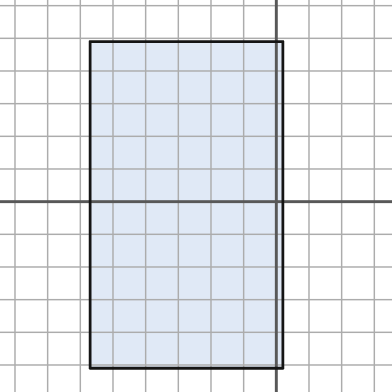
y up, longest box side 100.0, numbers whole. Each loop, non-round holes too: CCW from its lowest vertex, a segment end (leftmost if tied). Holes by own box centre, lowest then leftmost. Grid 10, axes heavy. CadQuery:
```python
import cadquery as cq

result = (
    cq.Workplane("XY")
    .moveTo(-57.0, -51.0)
    .lineTo(2.0, -51.0)
    .lineTo(2.0, 49.0)
    .lineTo(-57.0, 49.0)
    .close()
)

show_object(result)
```